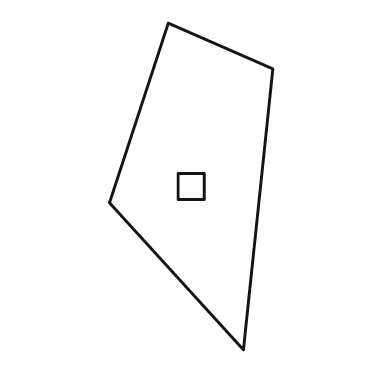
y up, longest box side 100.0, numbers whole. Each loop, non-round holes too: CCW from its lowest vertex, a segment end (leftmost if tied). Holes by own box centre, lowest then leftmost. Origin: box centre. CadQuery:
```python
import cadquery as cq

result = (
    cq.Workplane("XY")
    .moveTo(16.0, -50.0)
    .lineTo(25.0, 36.0)
    .lineTo(-7.0, 50.0)
    .lineTo(-25.0, -5.0)
    .close()
    .moveTo(-4.0, -4.0)
    .lineTo(4.0, -4.0)
    .lineTo(4.0, 4.0)
    .lineTo(-4.0, 4.0)
    .close()
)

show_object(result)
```